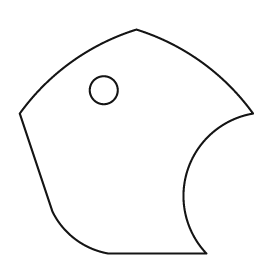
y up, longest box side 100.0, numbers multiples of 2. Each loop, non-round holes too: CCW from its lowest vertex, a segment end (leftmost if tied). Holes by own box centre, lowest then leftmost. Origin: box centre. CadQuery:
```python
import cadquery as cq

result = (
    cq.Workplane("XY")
    .moveTo(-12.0, -48.0)
    .lineTo(30.0, -48.0)
    .threePointArc((22.0, -12.0), (50.0, 12.0))
    .threePointArc((28.0, 34.0), (0.0, 48.0))
    .threePointArc((-28.0, 34.0), (-50.0, 12.0))
    .lineTo(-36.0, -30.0)
    .threePointArc((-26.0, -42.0), (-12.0, -48.0))
    .close()
    .moveTo(-14.0, 22.0)
    .circle(6.0)
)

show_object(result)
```